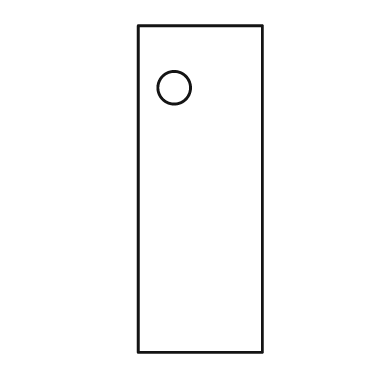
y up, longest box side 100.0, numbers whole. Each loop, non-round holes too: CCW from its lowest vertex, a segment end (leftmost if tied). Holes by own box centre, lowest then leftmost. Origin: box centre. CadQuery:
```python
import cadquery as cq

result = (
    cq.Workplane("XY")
    .moveTo(-19.0, -50.0)
    .lineTo(19.0, -50.0)
    .lineTo(19.0, 50.0)
    .lineTo(-19.0, 50.0)
    .close()
    .moveTo(-8.0, 31.0)
    .circle(5.0)
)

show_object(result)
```